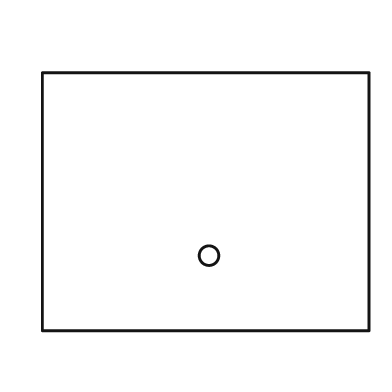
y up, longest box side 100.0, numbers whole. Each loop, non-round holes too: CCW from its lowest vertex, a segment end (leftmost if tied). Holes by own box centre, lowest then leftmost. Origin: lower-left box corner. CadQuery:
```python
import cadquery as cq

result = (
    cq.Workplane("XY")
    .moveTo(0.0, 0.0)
    .lineTo(100.0, 0.0)
    .lineTo(100.0, 79.0)
    .lineTo(0.0, 79.0)
    .close()
    .moveTo(51.0, 23.0)
    .circle(3.0)
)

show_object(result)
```